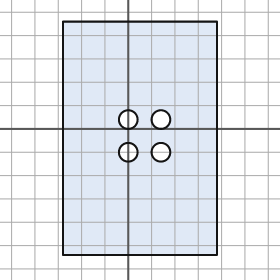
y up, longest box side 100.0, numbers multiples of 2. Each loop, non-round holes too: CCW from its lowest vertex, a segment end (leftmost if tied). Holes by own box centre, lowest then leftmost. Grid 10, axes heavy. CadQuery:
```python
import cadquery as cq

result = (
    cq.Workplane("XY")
    .moveTo(-28.0, -54.0)
    .lineTo(38.0, -54.0)
    .lineTo(38.0, 46.0)
    .lineTo(-28.0, 46.0)
    .close()
    .moveTo(0.0, -10.0)
    .circle(4.0)
    .moveTo(14.0, -10.0)
    .circle(4.0)
    .moveTo(0.0, 4.0)
    .circle(4.0)
    .moveTo(14.0, 4.0)
    .circle(4.0)
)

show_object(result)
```